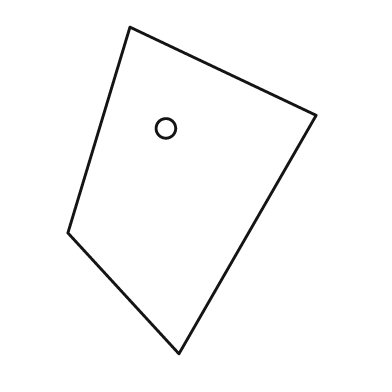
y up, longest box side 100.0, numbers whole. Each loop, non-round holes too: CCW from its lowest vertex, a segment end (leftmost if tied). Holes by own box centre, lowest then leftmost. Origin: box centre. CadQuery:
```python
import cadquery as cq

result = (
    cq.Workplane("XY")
    .moveTo(-4.0, -50.0)
    .lineTo(38.0, 23.0)
    .lineTo(-19.0, 50.0)
    .lineTo(-38.0, -13.0)
    .close()
    .moveTo(-8.0, 19.0)
    .circle(3.0)
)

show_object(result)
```